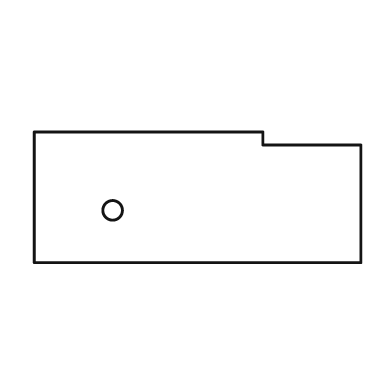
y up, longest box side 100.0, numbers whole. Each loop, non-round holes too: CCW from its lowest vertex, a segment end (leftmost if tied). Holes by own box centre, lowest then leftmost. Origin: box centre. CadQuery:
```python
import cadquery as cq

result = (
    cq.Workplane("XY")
    .moveTo(-50.0, -20.0)
    .lineTo(50.0, -20.0)
    .lineTo(50.0, 16.0)
    .lineTo(20.0, 16.0)
    .lineTo(20.0, 20.0)
    .lineTo(-50.0, 20.0)
    .close()
    .moveTo(-26.0, -4.0)
    .circle(3.0)
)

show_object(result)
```